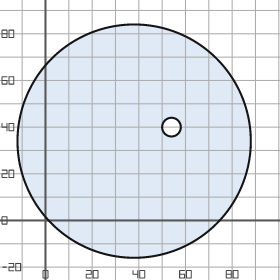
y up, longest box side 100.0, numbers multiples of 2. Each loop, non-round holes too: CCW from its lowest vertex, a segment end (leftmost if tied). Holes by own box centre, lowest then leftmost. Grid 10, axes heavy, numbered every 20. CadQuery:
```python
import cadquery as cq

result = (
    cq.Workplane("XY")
    .moveTo(38.0, 34.0)
    .circle(50.0)
    .moveTo(54.0, 40.0)
    .circle(4.0)
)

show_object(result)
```